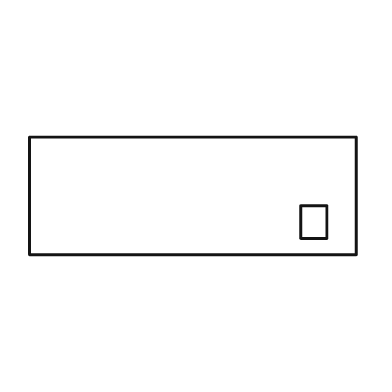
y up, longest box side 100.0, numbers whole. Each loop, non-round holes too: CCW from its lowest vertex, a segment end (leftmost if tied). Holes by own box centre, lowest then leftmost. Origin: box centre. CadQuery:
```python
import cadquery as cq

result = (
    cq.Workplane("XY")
    .moveTo(-50.0, -18.0)
    .lineTo(50.0, -18.0)
    .lineTo(50.0, 18.0)
    .lineTo(-50.0, 18.0)
    .close()
    .moveTo(33.0, -13.0)
    .lineTo(41.0, -13.0)
    .lineTo(41.0, -3.0)
    .lineTo(33.0, -3.0)
    .close()
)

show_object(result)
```